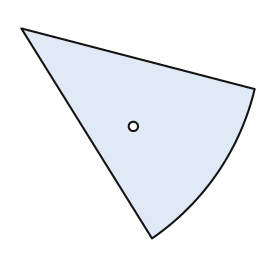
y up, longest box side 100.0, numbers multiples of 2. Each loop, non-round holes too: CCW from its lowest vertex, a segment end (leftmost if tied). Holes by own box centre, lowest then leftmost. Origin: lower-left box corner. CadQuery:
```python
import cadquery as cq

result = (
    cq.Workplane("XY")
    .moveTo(56.0, 0.0)
    .threePointArc((84.0, 28.0), (100.0, 64.0))
    .lineTo(0.0, 90.0)
    .close()
    .moveTo(48.0, 48.0)
    .circle(2.0)
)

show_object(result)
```